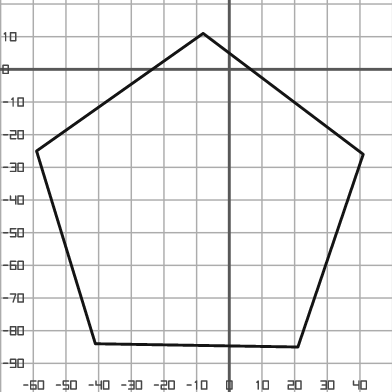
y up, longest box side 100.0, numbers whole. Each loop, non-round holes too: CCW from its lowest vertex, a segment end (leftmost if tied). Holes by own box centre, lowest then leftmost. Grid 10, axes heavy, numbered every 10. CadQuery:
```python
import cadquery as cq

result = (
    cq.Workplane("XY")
    .moveTo(21.0, -85.0)
    .lineTo(41.0, -26.0)
    .lineTo(-8.0, 11.0)
    .lineTo(-59.0, -25.0)
    .lineTo(-41.0, -84.0)
    .close()
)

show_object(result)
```